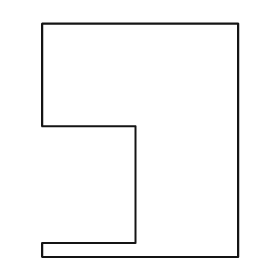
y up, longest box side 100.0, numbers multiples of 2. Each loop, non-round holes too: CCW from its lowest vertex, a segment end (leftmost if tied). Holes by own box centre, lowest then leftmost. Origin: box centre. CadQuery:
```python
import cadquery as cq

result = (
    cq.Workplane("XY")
    .moveTo(-42.0, -50.0)
    .lineTo(42.0, -50.0)
    .lineTo(42.0, 50.0)
    .lineTo(-42.0, 50.0)
    .lineTo(-42.0, 6.0)
    .lineTo(-2.0, 6.0)
    .lineTo(-2.0, -44.0)
    .lineTo(-42.0, -44.0)
    .close()
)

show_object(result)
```